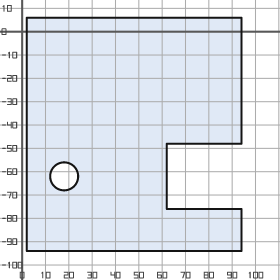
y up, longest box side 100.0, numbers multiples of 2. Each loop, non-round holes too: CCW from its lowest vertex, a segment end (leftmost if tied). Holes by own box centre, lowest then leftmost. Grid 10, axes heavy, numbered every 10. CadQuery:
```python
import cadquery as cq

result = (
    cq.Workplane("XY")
    .moveTo(2.0, -94.0)
    .lineTo(94.0, -94.0)
    .lineTo(94.0, -76.0)
    .lineTo(62.0, -76.0)
    .lineTo(62.0, -48.0)
    .lineTo(94.0, -48.0)
    .lineTo(94.0, 6.0)
    .lineTo(2.0, 6.0)
    .close()
    .moveTo(18.0, -62.0)
    .circle(6.0)
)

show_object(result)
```